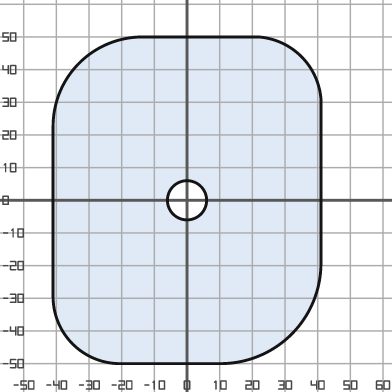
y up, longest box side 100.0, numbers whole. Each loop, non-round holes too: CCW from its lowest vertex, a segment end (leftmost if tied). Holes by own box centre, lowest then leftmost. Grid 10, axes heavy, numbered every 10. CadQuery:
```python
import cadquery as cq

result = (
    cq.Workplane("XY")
    .moveTo(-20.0, -50.0)
    .lineTo(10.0, -50.0)
    .threePointArc((32.0, -41.0), (41.0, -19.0))
    .lineTo(41.0, 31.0)
    .threePointArc((35.0, 44.0), (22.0, 50.0))
    .lineTo(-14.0, 50.0)
    .threePointArc((-33.0, 42.0), (-41.0, 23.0))
    .lineTo(-41.0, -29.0)
    .threePointArc((-35.0, -44.0), (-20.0, -50.0))
    .close()
    .moveTo(0.0, 0.0)
    .circle(6.0)
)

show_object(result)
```